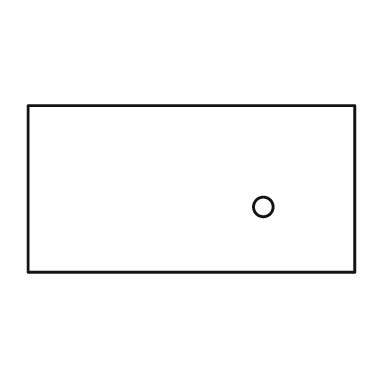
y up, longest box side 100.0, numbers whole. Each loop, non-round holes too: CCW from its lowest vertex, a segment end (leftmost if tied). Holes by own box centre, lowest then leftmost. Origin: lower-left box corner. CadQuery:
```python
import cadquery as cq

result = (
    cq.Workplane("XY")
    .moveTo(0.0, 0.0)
    .lineTo(100.0, 0.0)
    .lineTo(100.0, 51.0)
    .lineTo(0.0, 51.0)
    .close()
    .moveTo(72.0, 20.0)
    .circle(3.0)
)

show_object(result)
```